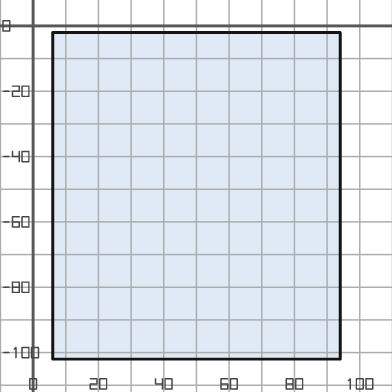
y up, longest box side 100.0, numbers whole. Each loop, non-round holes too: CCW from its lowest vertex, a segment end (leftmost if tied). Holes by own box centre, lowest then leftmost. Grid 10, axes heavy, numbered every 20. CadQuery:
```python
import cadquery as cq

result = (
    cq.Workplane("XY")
    .moveTo(6.0, -102.0)
    .lineTo(94.0, -102.0)
    .lineTo(94.0, -2.0)
    .lineTo(6.0, -2.0)
    .close()
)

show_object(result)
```